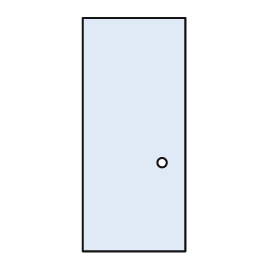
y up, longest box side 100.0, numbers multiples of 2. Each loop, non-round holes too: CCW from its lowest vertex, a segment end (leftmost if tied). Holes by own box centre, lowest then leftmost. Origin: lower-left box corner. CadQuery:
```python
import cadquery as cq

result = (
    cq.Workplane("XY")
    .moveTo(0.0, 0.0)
    .lineTo(44.0, 0.0)
    .lineTo(44.0, 100.0)
    .lineTo(0.0, 100.0)
    .close()
    .moveTo(34.0, 38.0)
    .circle(2.0)
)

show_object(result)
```